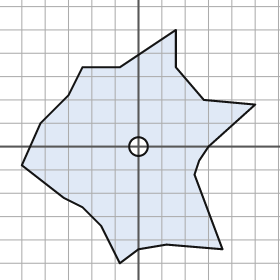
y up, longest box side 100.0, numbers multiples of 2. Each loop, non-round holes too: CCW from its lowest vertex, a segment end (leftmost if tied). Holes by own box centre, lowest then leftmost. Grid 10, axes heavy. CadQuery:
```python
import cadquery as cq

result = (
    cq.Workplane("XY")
    .moveTo(-8.0, -50.0)
    .lineTo(0.0, -44.0)
    .lineTo(12.0, -42.0)
    .lineTo(36.0, -44.0)
    .lineTo(24.0, -12.0)
    .lineTo(26.0, -6.0)
    .lineTo(30.0, 0.0)
    .lineTo(50.0, 18.0)
    .lineTo(28.0, 20.0)
    .lineTo(16.0, 34.0)
    .lineTo(16.0, 50.0)
    .lineTo(-8.0, 34.0)
    .lineTo(-24.0, 34.0)
    .lineTo(-30.0, 22.0)
    .lineTo(-42.0, 10.0)
    .lineTo(-50.0, -8.0)
    .lineTo(-32.0, -22.0)
    .lineTo(-24.0, -26.0)
    .lineTo(-16.0, -34.0)
    .close()
    .moveTo(0.0, 0.0)
    .circle(4.0)
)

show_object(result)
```